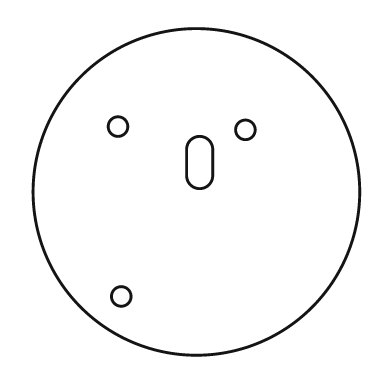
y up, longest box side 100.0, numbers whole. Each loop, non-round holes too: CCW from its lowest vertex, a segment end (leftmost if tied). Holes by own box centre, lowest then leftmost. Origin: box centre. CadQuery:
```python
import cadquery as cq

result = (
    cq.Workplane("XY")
    .moveTo(0.0, 0.0)
    .circle(50.0)
    .moveTo(-23.0, -32.0)
    .circle(3.0)
    .moveTo(-3.0, 5.0)
    .threePointArc((1.0, 1.0), (5.0, 5.0))
    .lineTo(5.0, 13.0)
    .threePointArc((1.0, 17.0), (-3.0, 13.0))
    .close()
    .moveTo(15.0, 19.0)
    .circle(3.0)
    .moveTo(-24.0, 20.0)
    .circle(3.0)
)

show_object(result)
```